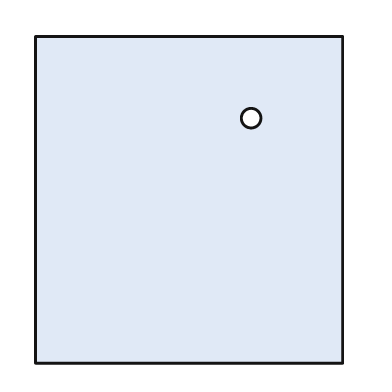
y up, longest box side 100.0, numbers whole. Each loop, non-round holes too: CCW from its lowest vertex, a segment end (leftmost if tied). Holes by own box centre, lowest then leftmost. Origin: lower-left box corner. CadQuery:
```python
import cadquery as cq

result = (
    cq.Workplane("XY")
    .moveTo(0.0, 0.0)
    .lineTo(94.0, 0.0)
    .lineTo(94.0, 100.0)
    .lineTo(0.0, 100.0)
    .close()
    .moveTo(66.0, 75.0)
    .circle(3.0)
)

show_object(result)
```